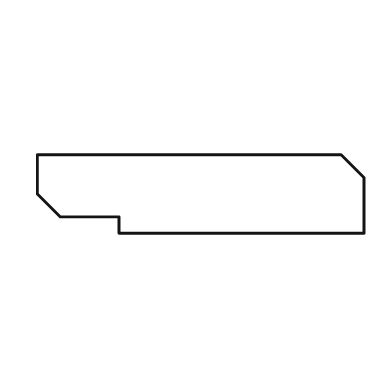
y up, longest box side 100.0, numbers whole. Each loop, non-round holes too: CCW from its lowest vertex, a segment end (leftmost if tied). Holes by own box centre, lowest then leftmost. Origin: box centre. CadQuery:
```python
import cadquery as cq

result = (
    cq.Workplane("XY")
    .moveTo(-25.0, -12.0)
    .lineTo(50.0, -12.0)
    .lineTo(50.0, 5.0)
    .lineTo(43.0, 12.0)
    .lineTo(-50.0, 12.0)
    .lineTo(-50.0, 0.0)
    .lineTo(-43.0, -7.0)
    .lineTo(-25.0, -7.0)
    .close()
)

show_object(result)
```